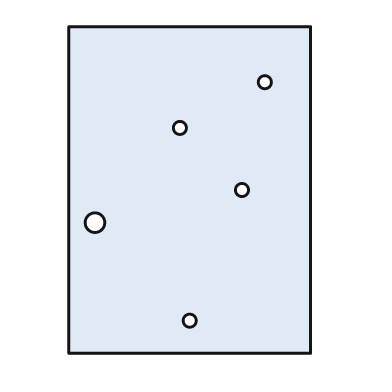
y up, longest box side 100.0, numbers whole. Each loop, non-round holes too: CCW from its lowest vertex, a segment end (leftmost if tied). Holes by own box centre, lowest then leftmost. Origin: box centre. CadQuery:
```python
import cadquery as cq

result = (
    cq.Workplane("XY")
    .moveTo(-37.0, -50.0)
    .lineTo(37.0, -50.0)
    .lineTo(37.0, 50.0)
    .lineTo(-37.0, 50.0)
    .close()
    .moveTo(0.0, -40.0)
    .circle(2.0)
    .moveTo(-29.0, -10.0)
    .circle(3.0)
    .moveTo(16.0, 0.0)
    .circle(2.0)
    .moveTo(-3.0, 19.0)
    .circle(2.0)
    .moveTo(23.0, 33.0)
    .circle(2.0)
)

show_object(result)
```